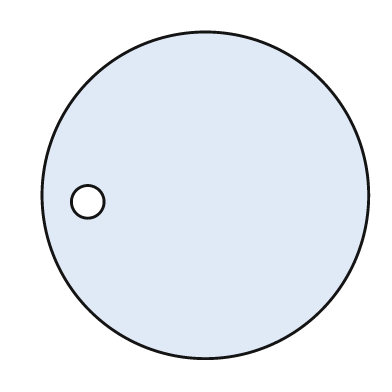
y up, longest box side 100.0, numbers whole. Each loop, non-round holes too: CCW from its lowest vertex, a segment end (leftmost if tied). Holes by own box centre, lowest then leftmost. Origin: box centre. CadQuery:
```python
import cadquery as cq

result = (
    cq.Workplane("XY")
    .moveTo(0.0, 0.0)
    .circle(50.0)
    .moveTo(-36.0, -2.0)
    .circle(5.0)
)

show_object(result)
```